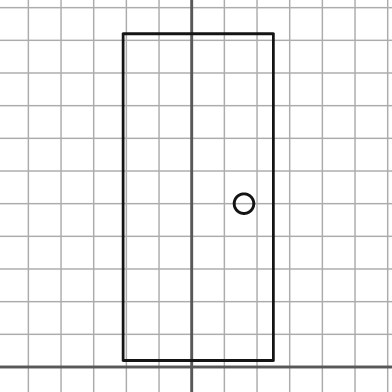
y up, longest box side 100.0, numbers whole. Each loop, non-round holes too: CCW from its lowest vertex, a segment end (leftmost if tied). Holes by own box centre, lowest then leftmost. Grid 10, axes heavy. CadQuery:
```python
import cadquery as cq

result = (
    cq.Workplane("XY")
    .moveTo(-21.0, 2.0)
    .lineTo(25.0, 2.0)
    .lineTo(25.0, 102.0)
    .lineTo(-21.0, 102.0)
    .close()
    .moveTo(16.0, 50.0)
    .circle(3.0)
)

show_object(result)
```